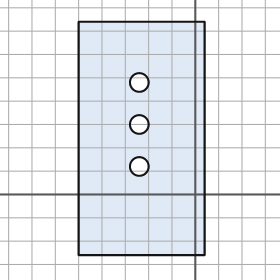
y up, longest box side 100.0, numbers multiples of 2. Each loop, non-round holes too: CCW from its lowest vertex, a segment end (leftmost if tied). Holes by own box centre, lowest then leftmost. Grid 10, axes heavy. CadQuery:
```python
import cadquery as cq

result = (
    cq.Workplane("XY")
    .moveTo(-50.0, -26.0)
    .lineTo(4.0, -26.0)
    .lineTo(4.0, 74.0)
    .lineTo(-50.0, 74.0)
    .close()
    .moveTo(-24.0, 12.0)
    .circle(4.0)
    .moveTo(-24.0, 30.0)
    .circle(4.0)
    .moveTo(-24.0, 48.0)
    .circle(4.0)
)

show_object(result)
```